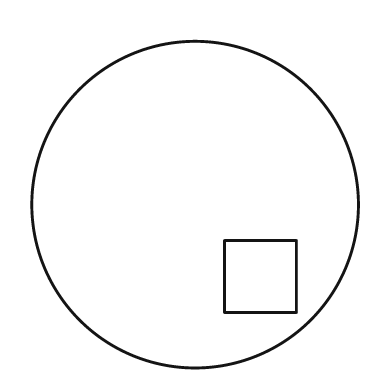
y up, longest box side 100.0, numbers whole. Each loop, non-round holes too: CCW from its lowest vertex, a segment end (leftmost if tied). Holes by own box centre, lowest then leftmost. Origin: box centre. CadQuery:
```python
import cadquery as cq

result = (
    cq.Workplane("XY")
    .moveTo(0.0, 0.0)
    .circle(50.0)
    .moveTo(9.0, -33.0)
    .lineTo(31.0, -33.0)
    .lineTo(31.0, -11.0)
    .lineTo(9.0, -11.0)
    .close()
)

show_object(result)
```